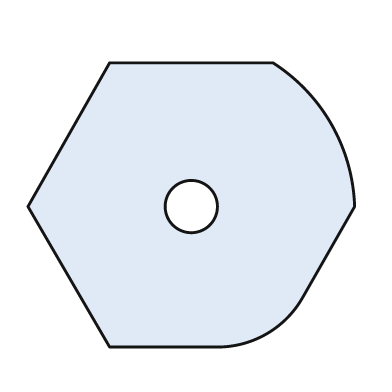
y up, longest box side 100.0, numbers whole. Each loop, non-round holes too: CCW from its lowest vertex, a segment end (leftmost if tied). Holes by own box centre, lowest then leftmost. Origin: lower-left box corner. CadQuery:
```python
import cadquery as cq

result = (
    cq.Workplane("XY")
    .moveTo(25.0, 0.0)
    .lineTo(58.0, 0.0)
    .threePointArc((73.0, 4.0), (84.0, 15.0))
    .lineTo(100.0, 43.0)
    .threePointArc((93.0, 68.0), (75.0, 87.0))
    .lineTo(25.0, 87.0)
    .lineTo(0.0, 43.0)
    .close()
    .moveTo(50.0, 43.0)
    .circle(8.0)
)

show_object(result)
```